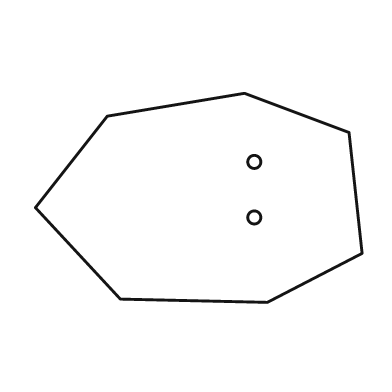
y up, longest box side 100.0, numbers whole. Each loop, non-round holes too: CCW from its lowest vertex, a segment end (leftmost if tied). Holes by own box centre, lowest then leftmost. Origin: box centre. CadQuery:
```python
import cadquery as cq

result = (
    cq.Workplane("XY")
    .moveTo(21.0, -32.0)
    .lineTo(50.0, -17.0)
    .lineTo(46.0, 20.0)
    .lineTo(14.0, 32.0)
    .lineTo(-28.0, 25.0)
    .lineTo(-50.0, -3.0)
    .lineTo(-24.0, -31.0)
    .close()
    .moveTo(17.0, -6.0)
    .circle(2.0)
    .moveTo(17.0, 11.0)
    .circle(2.0)
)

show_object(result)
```